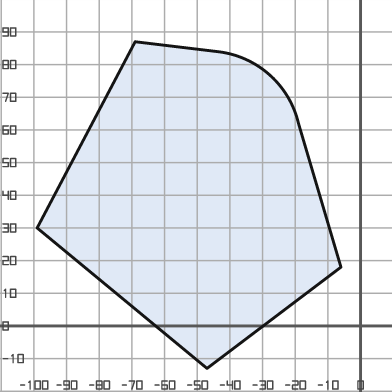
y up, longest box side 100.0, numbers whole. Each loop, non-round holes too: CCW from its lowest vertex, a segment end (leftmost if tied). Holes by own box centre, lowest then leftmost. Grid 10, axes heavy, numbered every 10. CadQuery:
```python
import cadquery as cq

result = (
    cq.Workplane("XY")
    .moveTo(-47.0, -13.0)
    .lineTo(-6.0, 18.0)
    .lineTo(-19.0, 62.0)
    .threePointArc((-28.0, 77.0), (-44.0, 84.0))
    .lineTo(-69.0, 87.0)
    .lineTo(-99.0, 30.0)
    .close()
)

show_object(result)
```